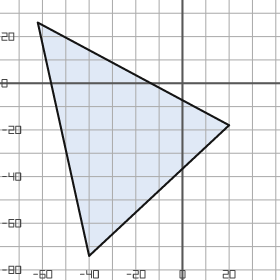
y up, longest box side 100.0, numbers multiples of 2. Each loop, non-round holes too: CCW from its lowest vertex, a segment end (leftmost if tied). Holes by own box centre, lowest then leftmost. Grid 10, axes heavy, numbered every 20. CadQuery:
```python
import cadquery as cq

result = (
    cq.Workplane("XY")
    .moveTo(-40.0, -74.0)
    .lineTo(20.0, -18.0)
    .lineTo(-62.0, 26.0)
    .close()
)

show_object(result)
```